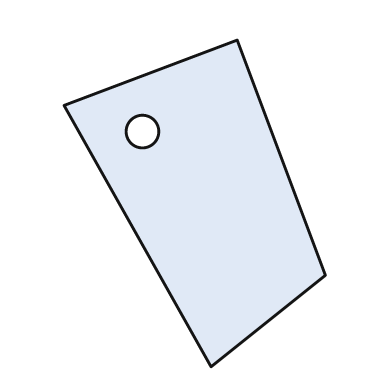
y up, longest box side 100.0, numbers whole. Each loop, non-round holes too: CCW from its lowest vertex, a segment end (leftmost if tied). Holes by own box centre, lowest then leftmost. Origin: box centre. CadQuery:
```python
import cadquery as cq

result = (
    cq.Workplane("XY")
    .moveTo(5.0, -50.0)
    .lineTo(40.0, -22.0)
    .lineTo(13.0, 50.0)
    .lineTo(-40.0, 30.0)
    .close()
    .moveTo(-16.0, 22.0)
    .circle(5.0)
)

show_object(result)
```